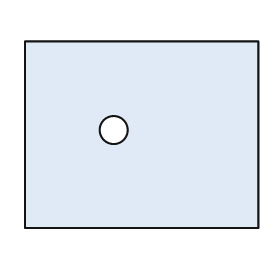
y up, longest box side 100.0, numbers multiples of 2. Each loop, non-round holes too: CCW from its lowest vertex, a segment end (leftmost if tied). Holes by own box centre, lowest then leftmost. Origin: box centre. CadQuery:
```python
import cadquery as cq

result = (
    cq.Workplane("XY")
    .moveTo(-50.0, -40.0)
    .lineTo(50.0, -40.0)
    .lineTo(50.0, 40.0)
    .lineTo(-50.0, 40.0)
    .close()
    .moveTo(-12.0, 2.0)
    .circle(6.0)
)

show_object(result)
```